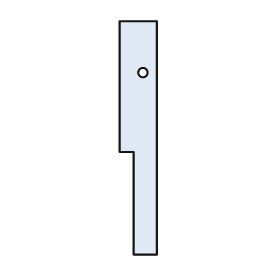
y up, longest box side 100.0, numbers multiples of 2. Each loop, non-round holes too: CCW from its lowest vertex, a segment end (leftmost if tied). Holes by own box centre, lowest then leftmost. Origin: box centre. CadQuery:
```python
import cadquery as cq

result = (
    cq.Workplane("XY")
    .moveTo(-2.0, -50.0)
    .lineTo(8.0, -50.0)
    .lineTo(8.0, 50.0)
    .lineTo(-8.0, 50.0)
    .lineTo(-8.0, -6.0)
    .lineTo(-2.0, -6.0)
    .close()
    .moveTo(2.0, 28.0)
    .circle(2.0)
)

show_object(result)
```